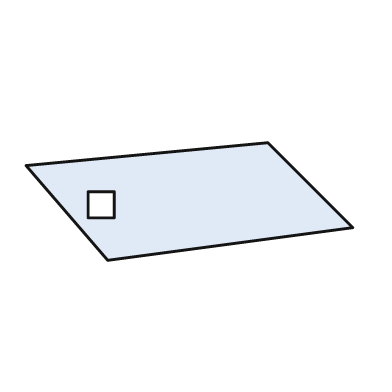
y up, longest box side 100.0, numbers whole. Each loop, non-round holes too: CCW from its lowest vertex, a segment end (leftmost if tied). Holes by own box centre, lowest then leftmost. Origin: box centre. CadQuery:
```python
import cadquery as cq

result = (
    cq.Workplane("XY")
    .moveTo(-25.0, -18.0)
    .lineTo(50.0, -8.0)
    .lineTo(24.0, 18.0)
    .lineTo(-50.0, 11.0)
    .close()
    .moveTo(-31.0, -5.0)
    .lineTo(-23.0, -5.0)
    .lineTo(-23.0, 3.0)
    .lineTo(-31.0, 3.0)
    .close()
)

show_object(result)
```